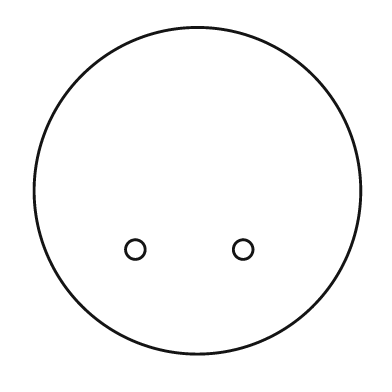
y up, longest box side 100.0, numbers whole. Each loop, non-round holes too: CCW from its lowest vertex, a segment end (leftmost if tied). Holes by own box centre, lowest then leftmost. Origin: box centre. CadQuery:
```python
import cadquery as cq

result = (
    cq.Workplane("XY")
    .moveTo(0.0, 0.0)
    .circle(50.0)
    .moveTo(-19.0, -18.0)
    .circle(3.0)
    .moveTo(14.0, -18.0)
    .circle(3.0)
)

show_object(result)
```